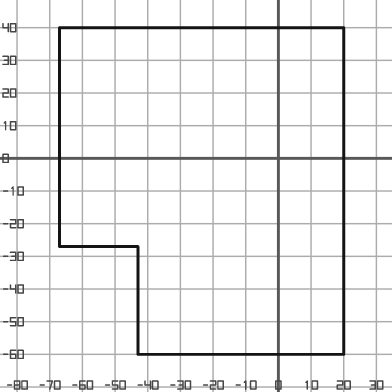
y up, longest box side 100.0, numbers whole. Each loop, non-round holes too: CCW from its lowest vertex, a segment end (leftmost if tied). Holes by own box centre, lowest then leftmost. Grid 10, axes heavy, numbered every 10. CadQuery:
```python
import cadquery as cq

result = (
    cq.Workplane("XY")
    .moveTo(-43.0, -60.0)
    .lineTo(20.0, -60.0)
    .lineTo(20.0, 40.0)
    .lineTo(-67.0, 40.0)
    .lineTo(-67.0, -27.0)
    .lineTo(-43.0, -27.0)
    .close()
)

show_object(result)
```